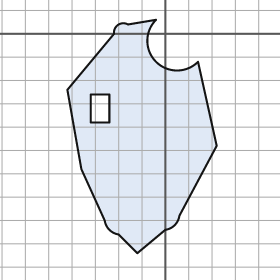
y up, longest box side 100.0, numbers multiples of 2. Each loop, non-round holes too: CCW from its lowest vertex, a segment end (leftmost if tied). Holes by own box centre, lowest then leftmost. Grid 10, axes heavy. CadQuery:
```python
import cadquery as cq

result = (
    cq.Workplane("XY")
    .moveTo(-12.0, -94.0)
    .lineTo(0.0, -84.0)
    .threePointArc((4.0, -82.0), (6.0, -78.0))
    .lineTo(22.0, -48.0)
    .lineTo(14.0, -12.0)
    .threePointArc((-4.0, -12.0), (-4.0, 6.0))
    .lineTo(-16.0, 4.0)
    .threePointArc((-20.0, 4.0), (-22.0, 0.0))
    .lineTo(-42.0, -24.0)
    .lineTo(-36.0, -58.0)
    .lineTo(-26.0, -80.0)
    .threePointArc((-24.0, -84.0), (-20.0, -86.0))
    .close()
    .moveTo(-32.0, -38.0)
    .lineTo(-24.0, -38.0)
    .lineTo(-24.0, -26.0)
    .lineTo(-32.0, -26.0)
    .close()
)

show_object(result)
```